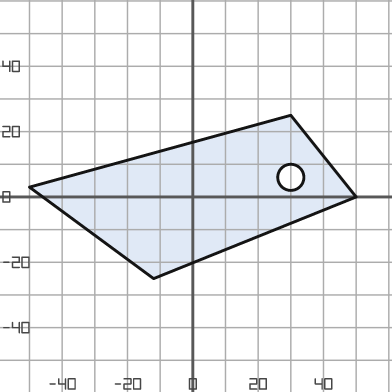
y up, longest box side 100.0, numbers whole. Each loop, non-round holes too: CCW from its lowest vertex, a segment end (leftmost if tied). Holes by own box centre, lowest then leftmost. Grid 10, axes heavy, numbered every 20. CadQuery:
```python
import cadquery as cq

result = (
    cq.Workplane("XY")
    .moveTo(-12.0, -25.0)
    .lineTo(50.0, 0.0)
    .lineTo(30.0, 25.0)
    .lineTo(-50.0, 3.0)
    .close()
    .moveTo(30.0, 6.0)
    .circle(4.0)
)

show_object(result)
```